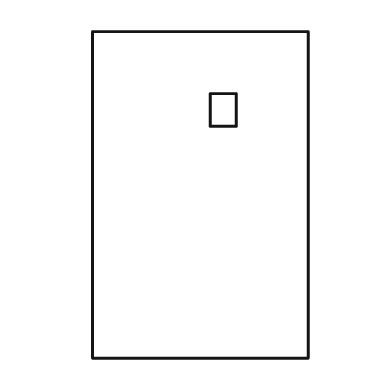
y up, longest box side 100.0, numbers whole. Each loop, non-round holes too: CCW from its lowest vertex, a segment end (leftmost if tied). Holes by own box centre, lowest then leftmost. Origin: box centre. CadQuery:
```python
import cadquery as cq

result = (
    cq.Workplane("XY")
    .moveTo(-33.0, -50.0)
    .lineTo(33.0, -50.0)
    .lineTo(33.0, 50.0)
    .lineTo(-33.0, 50.0)
    .close()
    .moveTo(3.0, 21.0)
    .lineTo(11.0, 21.0)
    .lineTo(11.0, 31.0)
    .lineTo(3.0, 31.0)
    .close()
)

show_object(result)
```